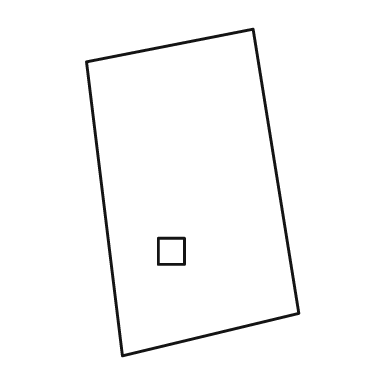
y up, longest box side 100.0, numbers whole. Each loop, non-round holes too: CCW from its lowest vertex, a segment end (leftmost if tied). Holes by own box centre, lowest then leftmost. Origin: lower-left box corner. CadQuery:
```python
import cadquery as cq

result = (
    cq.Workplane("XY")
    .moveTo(11.0, 0.0)
    .lineTo(65.0, 13.0)
    .lineTo(51.0, 100.0)
    .lineTo(0.0, 90.0)
    .close()
    .moveTo(22.0, 28.0)
    .lineTo(30.0, 28.0)
    .lineTo(30.0, 36.0)
    .lineTo(22.0, 36.0)
    .close()
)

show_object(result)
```